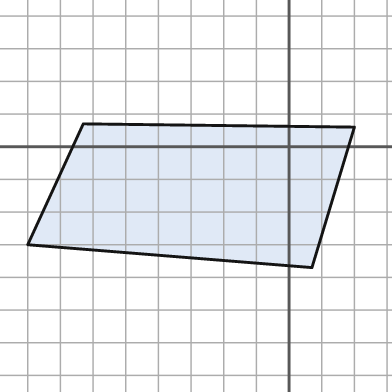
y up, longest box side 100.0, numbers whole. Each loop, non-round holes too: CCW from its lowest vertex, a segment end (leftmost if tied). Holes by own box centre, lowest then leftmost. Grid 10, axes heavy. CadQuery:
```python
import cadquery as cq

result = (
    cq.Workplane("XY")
    .moveTo(7.0, -37.0)
    .lineTo(20.0, 6.0)
    .lineTo(-63.0, 7.0)
    .lineTo(-80.0, -30.0)
    .close()
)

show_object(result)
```